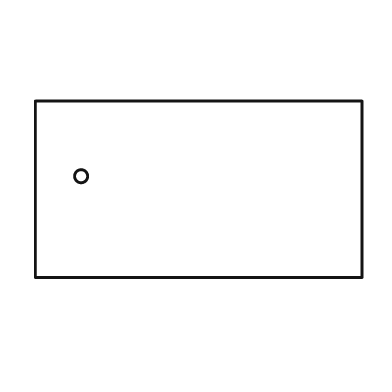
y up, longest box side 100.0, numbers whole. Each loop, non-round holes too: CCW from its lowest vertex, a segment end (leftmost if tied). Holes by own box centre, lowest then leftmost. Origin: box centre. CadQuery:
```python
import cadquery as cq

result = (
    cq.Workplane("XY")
    .moveTo(-50.0, -27.0)
    .lineTo(50.0, -27.0)
    .lineTo(50.0, 27.0)
    .lineTo(-50.0, 27.0)
    .close()
    .moveTo(-36.0, 4.0)
    .circle(2.0)
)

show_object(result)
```